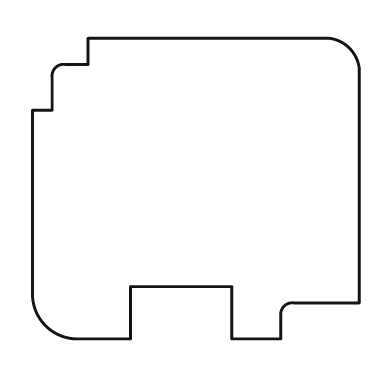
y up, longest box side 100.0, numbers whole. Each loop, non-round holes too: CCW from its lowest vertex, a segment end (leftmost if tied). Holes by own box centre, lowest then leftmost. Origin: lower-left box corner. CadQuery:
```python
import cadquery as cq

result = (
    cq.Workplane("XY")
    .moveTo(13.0, 0.0)
    .lineTo(30.0, 0.0)
    .lineTo(30.0, 16.0)
    .lineTo(61.0, 16.0)
    .lineTo(61.0, 0.0)
    .lineTo(76.0, 0.0)
    .lineTo(76.0, 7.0)
    .threePointArc((77.0, 10.0), (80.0, 11.0))
    .lineTo(100.0, 11.0)
    .lineTo(100.0, 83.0)
    .threePointArc((97.0, 89.0), (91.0, 92.0))
    .lineTo(17.0, 92.0)
    .lineTo(17.0, 84.0)
    .lineTo(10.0, 84.0)
    .threePointArc((7.0, 83.0), (6.0, 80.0))
    .lineTo(6.0, 70.0)
    .lineTo(0.0, 70.0)
    .lineTo(0.0, 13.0)
    .threePointArc((4.0, 4.0), (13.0, 0.0))
    .close()
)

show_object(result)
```